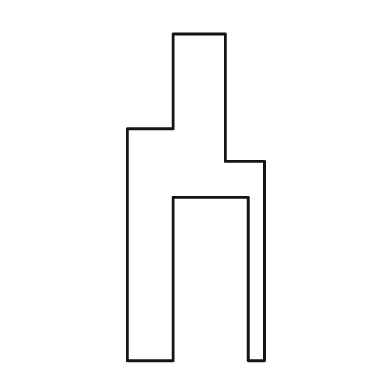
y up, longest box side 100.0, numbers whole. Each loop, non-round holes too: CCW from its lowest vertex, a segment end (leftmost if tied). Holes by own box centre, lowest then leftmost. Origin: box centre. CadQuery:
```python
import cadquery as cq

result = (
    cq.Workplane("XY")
    .moveTo(-21.0, -50.0)
    .lineTo(-7.0, -50.0)
    .lineTo(-7.0, 0.0)
    .lineTo(16.0, 0.0)
    .lineTo(16.0, -50.0)
    .lineTo(21.0, -50.0)
    .lineTo(21.0, 11.0)
    .lineTo(9.0, 11.0)
    .lineTo(9.0, 50.0)
    .lineTo(-7.0, 50.0)
    .lineTo(-7.0, 21.0)
    .lineTo(-21.0, 21.0)
    .close()
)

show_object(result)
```